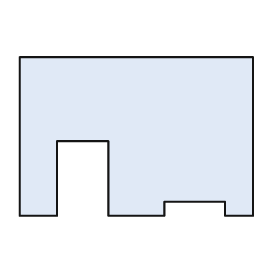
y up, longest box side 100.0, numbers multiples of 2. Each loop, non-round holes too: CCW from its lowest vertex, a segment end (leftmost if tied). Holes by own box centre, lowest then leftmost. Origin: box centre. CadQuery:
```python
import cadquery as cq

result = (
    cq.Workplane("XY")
    .moveTo(-50.0, -34.0)
    .lineTo(-34.0, -34.0)
    .lineTo(-34.0, -2.0)
    .lineTo(-12.0, -2.0)
    .lineTo(-12.0, -34.0)
    .lineTo(12.0, -34.0)
    .lineTo(12.0, -28.0)
    .lineTo(38.0, -28.0)
    .lineTo(38.0, -34.0)
    .lineTo(50.0, -34.0)
    .lineTo(50.0, 34.0)
    .lineTo(-50.0, 34.0)
    .close()
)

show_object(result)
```